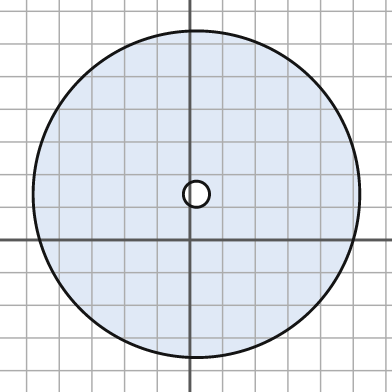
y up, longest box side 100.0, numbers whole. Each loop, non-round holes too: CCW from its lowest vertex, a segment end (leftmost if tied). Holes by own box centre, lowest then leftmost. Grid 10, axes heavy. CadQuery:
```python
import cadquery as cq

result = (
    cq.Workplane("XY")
    .moveTo(2.0, 14.0)
    .circle(50.0)
    .moveTo(2.0, 14.0)
    .circle(4.0)
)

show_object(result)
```